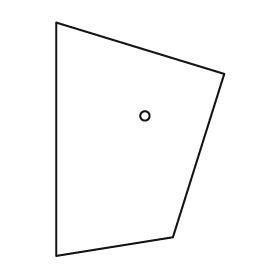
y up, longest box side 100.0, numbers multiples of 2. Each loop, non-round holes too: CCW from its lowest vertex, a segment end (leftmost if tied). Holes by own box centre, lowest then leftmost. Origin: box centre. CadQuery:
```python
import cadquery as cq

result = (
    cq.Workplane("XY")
    .moveTo(-36.0, -50.0)
    .lineTo(14.0, -42.0)
    .lineTo(36.0, 28.0)
    .lineTo(-36.0, 50.0)
    .close()
    .moveTo(2.0, 10.0)
    .circle(2.0)
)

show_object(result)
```